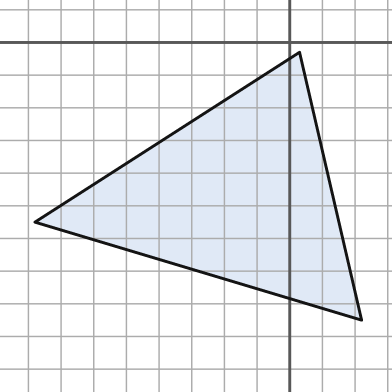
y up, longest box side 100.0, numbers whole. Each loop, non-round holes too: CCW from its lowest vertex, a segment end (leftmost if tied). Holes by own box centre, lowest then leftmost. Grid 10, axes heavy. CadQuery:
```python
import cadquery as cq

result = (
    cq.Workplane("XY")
    .moveTo(22.0, -85.0)
    .lineTo(3.0, -3.0)
    .lineTo(-78.0, -55.0)
    .close()
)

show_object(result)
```